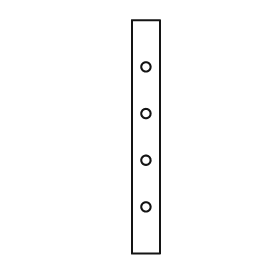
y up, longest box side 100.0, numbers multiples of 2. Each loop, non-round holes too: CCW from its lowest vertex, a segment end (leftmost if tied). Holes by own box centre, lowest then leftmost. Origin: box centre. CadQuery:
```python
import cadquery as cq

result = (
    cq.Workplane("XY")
    .moveTo(-6.0, -50.0)
    .lineTo(6.0, -50.0)
    .lineTo(6.0, 50.0)
    .lineTo(-6.0, 50.0)
    .close()
    .moveTo(0.0, -30.0)
    .circle(2.0)
    .moveTo(0.0, -10.0)
    .circle(2.0)
    .moveTo(0.0, 10.0)
    .circle(2.0)
    .moveTo(0.0, 30.0)
    .circle(2.0)
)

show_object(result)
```